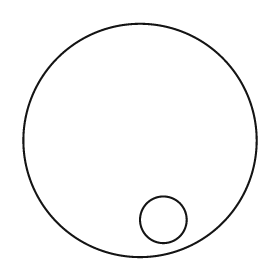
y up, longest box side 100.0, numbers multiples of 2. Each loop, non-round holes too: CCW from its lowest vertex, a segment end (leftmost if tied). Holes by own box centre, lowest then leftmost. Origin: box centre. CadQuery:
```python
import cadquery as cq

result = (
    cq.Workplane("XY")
    .moveTo(0.0, 0.0)
    .circle(50.0)
    .moveTo(10.0, -34.0)
    .circle(10.0)
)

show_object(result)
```